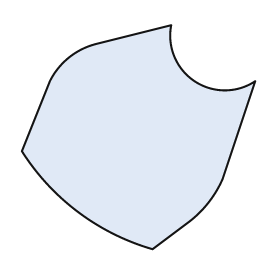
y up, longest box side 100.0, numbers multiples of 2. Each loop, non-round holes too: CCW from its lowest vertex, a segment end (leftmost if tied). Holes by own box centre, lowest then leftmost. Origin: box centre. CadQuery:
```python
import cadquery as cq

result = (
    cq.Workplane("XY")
    .moveTo(6.0, -48.0)
    .lineTo(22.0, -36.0)
    .threePointArc((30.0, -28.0), (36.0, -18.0))
    .lineTo(50.0, 24.0)
    .threePointArc((24.0, 24.0), (14.0, 48.0))
    .lineTo(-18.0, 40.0)
    .threePointArc((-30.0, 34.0), (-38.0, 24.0))
    .lineTo(-50.0, -6.0)
    .threePointArc((-26.0, -32.0), (6.0, -48.0))
    .close()
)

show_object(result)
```